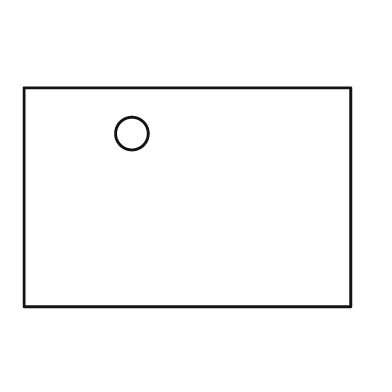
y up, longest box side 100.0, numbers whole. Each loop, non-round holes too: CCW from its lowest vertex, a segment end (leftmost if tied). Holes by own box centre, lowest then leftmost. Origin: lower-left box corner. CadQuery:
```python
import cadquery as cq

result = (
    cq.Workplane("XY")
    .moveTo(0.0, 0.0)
    .lineTo(100.0, 0.0)
    .lineTo(100.0, 67.0)
    .lineTo(0.0, 67.0)
    .close()
    .moveTo(33.0, 53.0)
    .circle(5.0)
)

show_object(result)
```